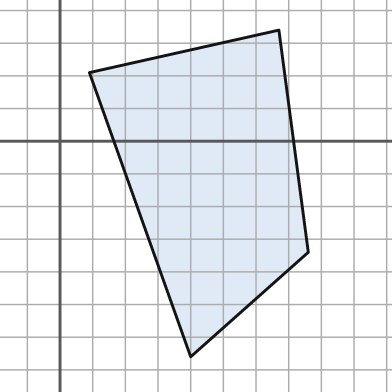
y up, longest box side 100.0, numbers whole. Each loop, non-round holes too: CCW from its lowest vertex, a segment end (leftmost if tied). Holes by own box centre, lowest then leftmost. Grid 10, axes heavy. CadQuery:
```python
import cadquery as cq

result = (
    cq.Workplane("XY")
    .moveTo(40.0, -66.0)
    .lineTo(76.0, -34.0)
    .lineTo(67.0, 34.0)
    .lineTo(9.0, 21.0)
    .close()
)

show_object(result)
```